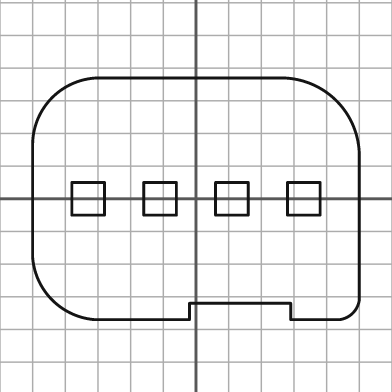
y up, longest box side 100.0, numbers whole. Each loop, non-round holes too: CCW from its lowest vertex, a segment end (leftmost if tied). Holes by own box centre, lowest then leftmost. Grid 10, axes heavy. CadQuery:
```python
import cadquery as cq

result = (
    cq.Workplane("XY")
    .moveTo(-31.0, -37.0)
    .lineTo(-2.0, -37.0)
    .lineTo(-2.0, -32.0)
    .lineTo(29.0, -32.0)
    .lineTo(29.0, -37.0)
    .lineTo(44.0, -37.0)
    .threePointArc((48.0, -35.0), (50.0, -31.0))
    .lineTo(50.0, 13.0)
    .threePointArc((43.0, 30.0), (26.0, 37.0))
    .lineTo(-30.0, 37.0)
    .threePointArc((-44.0, 31.0), (-50.0, 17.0))
    .lineTo(-50.0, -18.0)
    .threePointArc((-44.0, -31.0), (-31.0, -37.0))
    .close()
    .moveTo(-38.0, -5.0)
    .lineTo(-28.0, -5.0)
    .lineTo(-28.0, 5.0)
    .lineTo(-38.0, 5.0)
    .close()
    .moveTo(-16.0, -5.0)
    .lineTo(-6.0, -5.0)
    .lineTo(-6.0, 5.0)
    .lineTo(-16.0, 5.0)
    .close()
    .moveTo(6.0, -5.0)
    .lineTo(16.0, -5.0)
    .lineTo(16.0, 5.0)
    .lineTo(6.0, 5.0)
    .close()
    .moveTo(28.0, -5.0)
    .lineTo(38.0, -5.0)
    .lineTo(38.0, 5.0)
    .lineTo(28.0, 5.0)
    .close()
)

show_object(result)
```